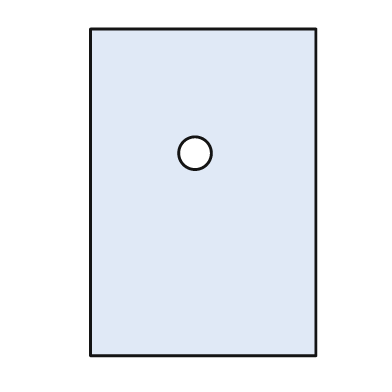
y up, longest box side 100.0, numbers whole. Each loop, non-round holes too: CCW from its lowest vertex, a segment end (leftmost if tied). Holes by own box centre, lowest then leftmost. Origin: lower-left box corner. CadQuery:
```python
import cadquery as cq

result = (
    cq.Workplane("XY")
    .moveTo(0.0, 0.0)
    .lineTo(69.0, 0.0)
    .lineTo(69.0, 100.0)
    .lineTo(0.0, 100.0)
    .close()
    .moveTo(32.0, 62.0)
    .circle(5.0)
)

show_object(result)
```